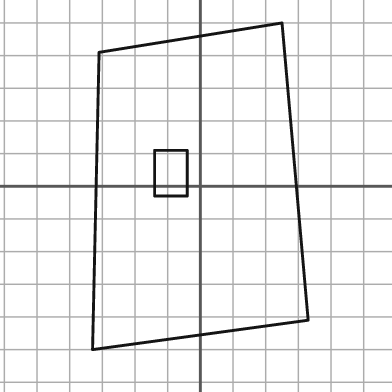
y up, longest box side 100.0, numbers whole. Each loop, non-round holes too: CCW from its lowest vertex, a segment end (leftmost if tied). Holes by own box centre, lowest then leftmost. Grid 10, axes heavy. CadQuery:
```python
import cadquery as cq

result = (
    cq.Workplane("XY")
    .moveTo(-33.0, -50.0)
    .lineTo(33.0, -41.0)
    .lineTo(25.0, 50.0)
    .lineTo(-31.0, 41.0)
    .close()
    .moveTo(-14.0, -3.0)
    .lineTo(-4.0, -3.0)
    .lineTo(-4.0, 11.0)
    .lineTo(-14.0, 11.0)
    .close()
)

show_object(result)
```